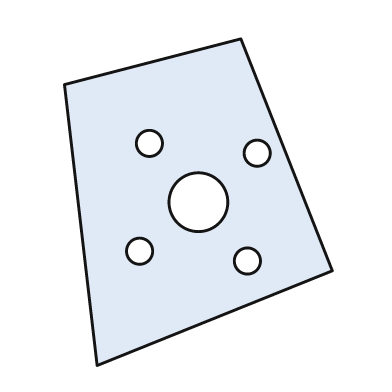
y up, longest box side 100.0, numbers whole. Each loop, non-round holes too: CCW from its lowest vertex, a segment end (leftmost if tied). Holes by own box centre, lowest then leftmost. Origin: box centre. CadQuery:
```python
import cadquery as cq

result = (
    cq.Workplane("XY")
    .moveTo(-31.0, -50.0)
    .lineTo(41.0, -21.0)
    .lineTo(13.0, 50.0)
    .lineTo(-41.0, 36.0)
    .close()
    .moveTo(15.0, -18.0)
    .circle(4.0)
    .moveTo(-18.0, -15.0)
    .circle(4.0)
    .moveTo(0.0, 0.0)
    .circle(9.0)
    .moveTo(18.0, 15.0)
    .circle(4.0)
    .moveTo(-15.0, 18.0)
    .circle(4.0)
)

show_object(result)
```